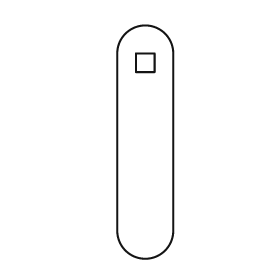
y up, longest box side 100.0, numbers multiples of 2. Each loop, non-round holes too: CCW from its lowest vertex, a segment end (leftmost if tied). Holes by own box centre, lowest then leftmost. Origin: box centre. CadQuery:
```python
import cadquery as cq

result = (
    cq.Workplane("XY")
    .moveTo(-12.0, -38.0)
    .threePointArc((0.0, -50.0), (12.0, -38.0))
    .lineTo(12.0, 38.0)
    .threePointArc((0.0, 50.0), (-12.0, 38.0))
    .close()
    .moveTo(-4.0, 30.0)
    .lineTo(4.0, 30.0)
    .lineTo(4.0, 38.0)
    .lineTo(-4.0, 38.0)
    .close()
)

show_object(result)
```